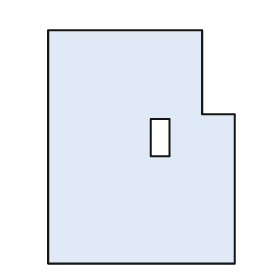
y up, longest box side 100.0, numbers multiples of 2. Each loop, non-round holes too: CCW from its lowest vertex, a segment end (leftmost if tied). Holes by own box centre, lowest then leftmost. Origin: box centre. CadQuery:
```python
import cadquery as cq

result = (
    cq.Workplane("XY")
    .moveTo(-40.0, -50.0)
    .lineTo(40.0, -50.0)
    .lineTo(40.0, 14.0)
    .lineTo(26.0, 14.0)
    .lineTo(26.0, 50.0)
    .lineTo(-40.0, 50.0)
    .close()
    .moveTo(4.0, -4.0)
    .lineTo(12.0, -4.0)
    .lineTo(12.0, 12.0)
    .lineTo(4.0, 12.0)
    .close()
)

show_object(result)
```